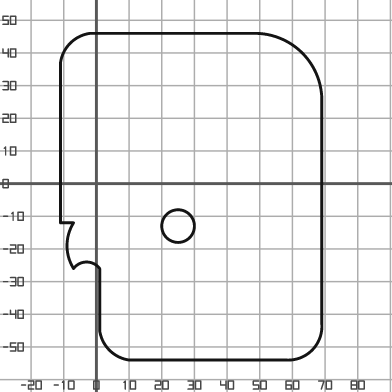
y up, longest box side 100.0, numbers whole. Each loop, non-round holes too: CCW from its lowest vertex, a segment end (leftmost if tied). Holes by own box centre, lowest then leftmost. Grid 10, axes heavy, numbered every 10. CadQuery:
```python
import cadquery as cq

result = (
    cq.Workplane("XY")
    .moveTo(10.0, -54.0)
    .lineTo(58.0, -54.0)
    .threePointArc((66.0, -51.0), (69.0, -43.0))
    .lineTo(69.0, 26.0)
    .threePointArc((63.0, 40.0), (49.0, 46.0))
    .lineTo(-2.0, 46.0)
    .threePointArc((-8.0, 43.0), (-11.0, 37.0))
    .lineTo(-11.0, -12.0)
    .lineTo(-7.0, -12.0)
    .threePointArc((-9.0, -19.0), (-7.0, -26.0))
    .threePointArc((-3.0, -24.0), (1.0, -26.0))
    .lineTo(1.0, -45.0)
    .threePointArc((4.0, -51.0), (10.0, -54.0))
    .close()
    .moveTo(25.0, -13.0)
    .circle(5.0)
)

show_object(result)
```